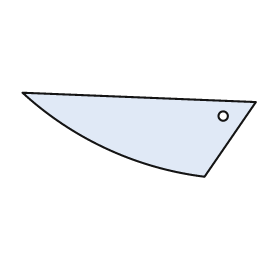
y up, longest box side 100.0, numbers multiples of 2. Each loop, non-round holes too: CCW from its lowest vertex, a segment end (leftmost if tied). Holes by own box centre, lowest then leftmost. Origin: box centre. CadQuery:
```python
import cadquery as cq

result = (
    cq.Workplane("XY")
    .moveTo(28.0, -18.0)
    .lineTo(50.0, 14.0)
    .lineTo(-50.0, 18.0)
    .threePointArc((-14.0, -6.0), (28.0, -18.0))
    .close()
    .moveTo(36.0, 8.0)
    .circle(2.0)
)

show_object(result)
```